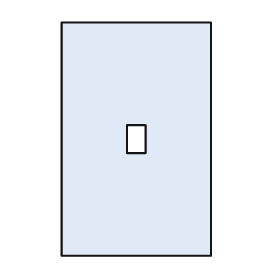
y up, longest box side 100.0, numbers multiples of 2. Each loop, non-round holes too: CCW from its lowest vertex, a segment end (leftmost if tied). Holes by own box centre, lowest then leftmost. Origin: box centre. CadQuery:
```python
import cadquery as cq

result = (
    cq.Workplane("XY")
    .moveTo(-32.0, -50.0)
    .lineTo(32.0, -50.0)
    .lineTo(32.0, 50.0)
    .lineTo(-32.0, 50.0)
    .close()
    .moveTo(-4.0, -6.0)
    .lineTo(4.0, -6.0)
    .lineTo(4.0, 6.0)
    .lineTo(-4.0, 6.0)
    .close()
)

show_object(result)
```